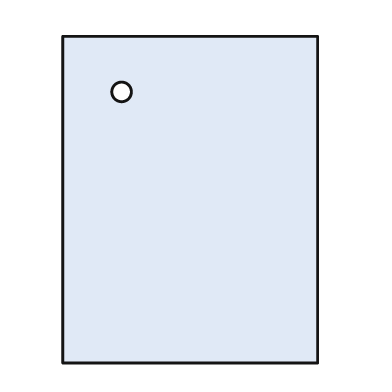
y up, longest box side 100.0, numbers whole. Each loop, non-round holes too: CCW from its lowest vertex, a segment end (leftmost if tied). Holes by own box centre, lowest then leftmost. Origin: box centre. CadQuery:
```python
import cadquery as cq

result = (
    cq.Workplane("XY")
    .moveTo(-39.0, -50.0)
    .lineTo(39.0, -50.0)
    .lineTo(39.0, 50.0)
    .lineTo(-39.0, 50.0)
    .close()
    .moveTo(-21.0, 33.0)
    .circle(3.0)
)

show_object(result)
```